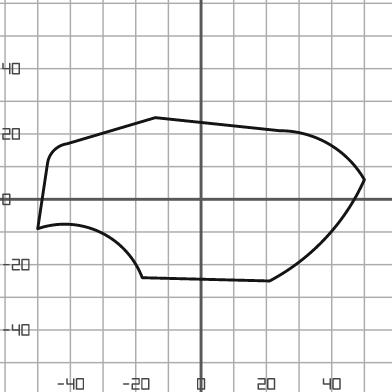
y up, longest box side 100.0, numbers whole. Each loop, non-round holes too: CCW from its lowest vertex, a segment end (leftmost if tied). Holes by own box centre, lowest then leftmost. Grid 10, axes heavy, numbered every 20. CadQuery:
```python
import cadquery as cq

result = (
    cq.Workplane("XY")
    .moveTo(21.0, -25.0)
    .threePointArc((38.0, -12.0), (50.0, 6.0))
    .threePointArc((39.0, 17.0), (24.0, 21.0))
    .lineTo(-14.0, 25.0)
    .lineTo(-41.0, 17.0)
    .threePointArc((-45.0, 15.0), (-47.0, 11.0))
    .lineTo(-50.0, -9.0)
    .threePointArc((-31.0, -10.0), (-18.0, -24.0))
    .close()
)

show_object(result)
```